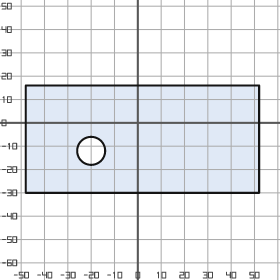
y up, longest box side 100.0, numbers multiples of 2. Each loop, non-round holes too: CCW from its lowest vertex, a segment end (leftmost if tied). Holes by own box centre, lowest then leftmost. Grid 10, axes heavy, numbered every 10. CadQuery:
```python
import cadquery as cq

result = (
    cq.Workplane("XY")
    .moveTo(-48.0, -30.0)
    .lineTo(52.0, -30.0)
    .lineTo(52.0, 16.0)
    .lineTo(-48.0, 16.0)
    .close()
    .moveTo(-20.0, -12.0)
    .circle(6.0)
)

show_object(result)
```